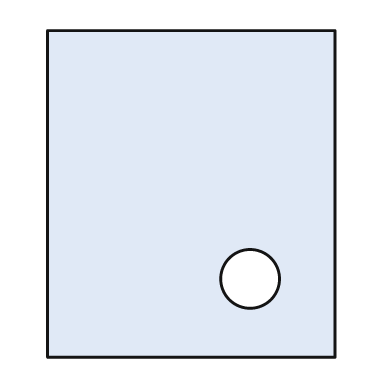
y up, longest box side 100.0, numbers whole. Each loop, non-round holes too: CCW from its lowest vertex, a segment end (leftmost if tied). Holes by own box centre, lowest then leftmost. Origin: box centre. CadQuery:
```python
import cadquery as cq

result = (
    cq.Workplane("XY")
    .moveTo(-44.0, -50.0)
    .lineTo(44.0, -50.0)
    .lineTo(44.0, 50.0)
    .lineTo(-44.0, 50.0)
    .close()
    .moveTo(18.0, -26.0)
    .circle(9.0)
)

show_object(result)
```